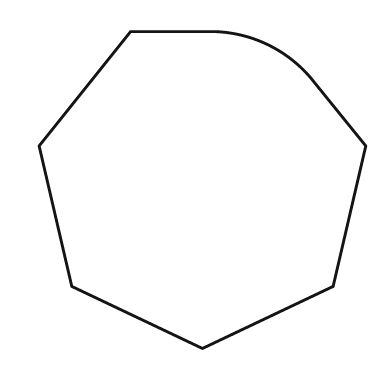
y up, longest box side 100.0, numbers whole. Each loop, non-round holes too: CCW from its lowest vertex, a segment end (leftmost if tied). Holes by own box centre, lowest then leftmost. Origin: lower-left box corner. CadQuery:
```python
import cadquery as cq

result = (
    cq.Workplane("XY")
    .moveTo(50.0, 0.0)
    .lineTo(90.0, 19.0)
    .lineTo(100.0, 62.0)
    .lineTo(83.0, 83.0)
    .threePointArc((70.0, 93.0), (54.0, 97.0))
    .lineTo(28.0, 97.0)
    .lineTo(0.0, 62.0)
    .lineTo(10.0, 19.0)
    .close()
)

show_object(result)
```